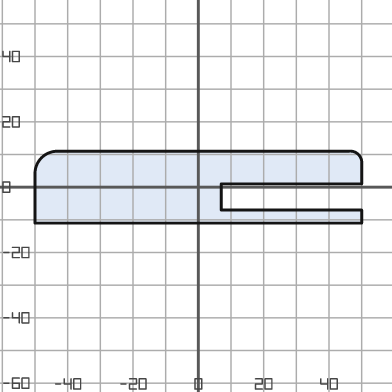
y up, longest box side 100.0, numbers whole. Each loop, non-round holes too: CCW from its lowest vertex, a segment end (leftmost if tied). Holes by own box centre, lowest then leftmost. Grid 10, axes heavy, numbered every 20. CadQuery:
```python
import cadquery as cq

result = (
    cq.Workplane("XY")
    .moveTo(-50.0, -11.0)
    .lineTo(50.0, -11.0)
    .lineTo(50.0, -7.0)
    .lineTo(7.0, -7.0)
    .lineTo(7.0, 1.0)
    .lineTo(50.0, 1.0)
    .lineTo(50.0, 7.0)
    .threePointArc((49.0, 10.0), (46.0, 11.0))
    .lineTo(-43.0, 11.0)
    .threePointArc((-48.0, 9.0), (-50.0, 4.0))
    .close()
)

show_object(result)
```